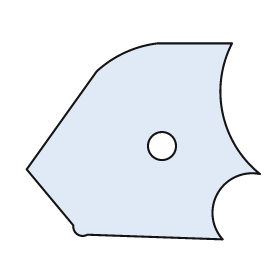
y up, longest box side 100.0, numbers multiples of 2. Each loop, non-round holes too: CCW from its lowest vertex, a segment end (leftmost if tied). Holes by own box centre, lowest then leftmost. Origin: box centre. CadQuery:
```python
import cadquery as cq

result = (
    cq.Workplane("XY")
    .moveTo(34.0, -42.0)
    .threePointArc((32.0, -22.0), (50.0, -14.0))
    .threePointArc((34.0, 12.0), (38.0, 42.0))
    .lineTo(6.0, 42.0)
    .threePointArc((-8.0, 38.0), (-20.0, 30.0))
    .lineTo(-50.0, -12.0)
    .lineTo(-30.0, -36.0)
    .threePointArc((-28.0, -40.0), (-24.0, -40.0))
    .close()
    .moveTo(8.0, -2.0)
    .circle(6.0)
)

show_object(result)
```